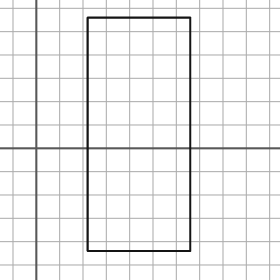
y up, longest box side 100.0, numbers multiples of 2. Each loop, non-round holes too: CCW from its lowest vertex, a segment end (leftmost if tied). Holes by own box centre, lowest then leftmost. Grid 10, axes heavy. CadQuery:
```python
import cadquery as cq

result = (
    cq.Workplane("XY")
    .moveTo(22.0, -44.0)
    .lineTo(66.0, -44.0)
    .lineTo(66.0, 56.0)
    .lineTo(22.0, 56.0)
    .close()
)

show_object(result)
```